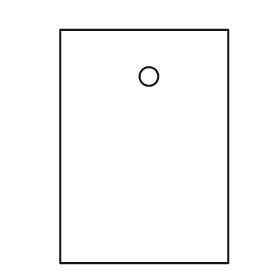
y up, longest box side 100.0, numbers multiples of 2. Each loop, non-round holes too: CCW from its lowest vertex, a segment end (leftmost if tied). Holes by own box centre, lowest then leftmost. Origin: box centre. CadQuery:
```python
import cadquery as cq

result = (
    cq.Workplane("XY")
    .moveTo(-36.0, -50.0)
    .lineTo(36.0, -50.0)
    .lineTo(36.0, 50.0)
    .lineTo(-36.0, 50.0)
    .close()
    .moveTo(2.0, 30.0)
    .circle(4.0)
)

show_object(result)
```